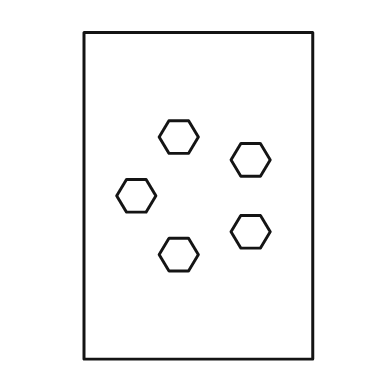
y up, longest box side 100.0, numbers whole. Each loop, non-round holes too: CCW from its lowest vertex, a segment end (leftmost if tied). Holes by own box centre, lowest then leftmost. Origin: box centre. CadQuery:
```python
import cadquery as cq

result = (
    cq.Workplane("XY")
    .moveTo(-35.0, -50.0)
    .lineTo(35.0, -50.0)
    .lineTo(35.0, 50.0)
    .lineTo(-35.0, 50.0)
    .close()
    .moveTo(-9.0, -23.0)
    .lineTo(-3.0, -23.0)
    .lineTo(0.0, -18.0)
    .lineTo(-3.0, -13.0)
    .lineTo(-9.0, -13.0)
    .lineTo(-12.0, -18.0)
    .close()
    .moveTo(13.0, -16.0)
    .lineTo(19.0, -16.0)
    .lineTo(22.0, -11.0)
    .lineTo(19.0, -6.0)
    .lineTo(13.0, -6.0)
    .lineTo(10.0, -11.0)
    .close()
    .moveTo(-22.0, -5.0)
    .lineTo(-16.0, -5.0)
    .lineTo(-13.0, 0.0)
    .lineTo(-16.0, 5.0)
    .lineTo(-22.0, 5.0)
    .lineTo(-25.0, 0.0)
    .close()
    .moveTo(13.0, 6.0)
    .lineTo(19.0, 6.0)
    .lineTo(22.0, 11.0)
    .lineTo(19.0, 16.0)
    .lineTo(13.0, 16.0)
    .lineTo(10.0, 11.0)
    .close()
    .moveTo(-9.0, 13.0)
    .lineTo(-3.0, 13.0)
    .lineTo(0.0, 18.0)
    .lineTo(-3.0, 23.0)
    .lineTo(-9.0, 23.0)
    .lineTo(-12.0, 18.0)
    .close()
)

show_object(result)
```